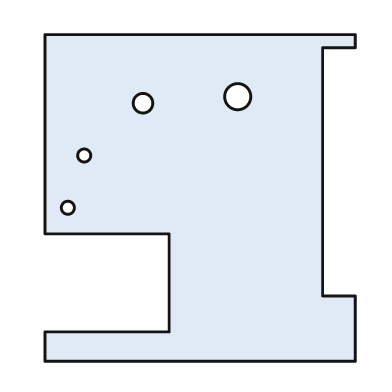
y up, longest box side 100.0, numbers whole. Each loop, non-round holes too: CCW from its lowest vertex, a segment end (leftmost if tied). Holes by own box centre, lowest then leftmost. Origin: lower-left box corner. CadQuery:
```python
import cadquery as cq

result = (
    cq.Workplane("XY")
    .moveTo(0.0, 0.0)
    .lineTo(95.0, 0.0)
    .lineTo(95.0, 20.0)
    .lineTo(85.0, 20.0)
    .lineTo(85.0, 96.0)
    .lineTo(95.0, 96.0)
    .lineTo(95.0, 100.0)
    .lineTo(0.0, 100.0)
    .lineTo(0.0, 39.0)
    .lineTo(38.0, 39.0)
    .lineTo(38.0, 9.0)
    .lineTo(0.0, 9.0)
    .close()
    .moveTo(7.0, 47.0)
    .circle(2.0)
    .moveTo(12.0, 63.0)
    .circle(2.0)
    .moveTo(30.0, 79.0)
    .circle(3.0)
    .moveTo(59.0, 81.0)
    .circle(4.0)
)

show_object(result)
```